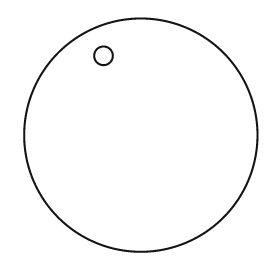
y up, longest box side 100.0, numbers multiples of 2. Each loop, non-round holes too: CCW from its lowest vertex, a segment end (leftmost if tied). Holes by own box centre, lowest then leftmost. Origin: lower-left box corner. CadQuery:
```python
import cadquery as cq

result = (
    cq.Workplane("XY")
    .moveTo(50.0, 50.0)
    .circle(50.0)
    .moveTo(34.0, 84.0)
    .circle(4.0)
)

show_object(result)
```